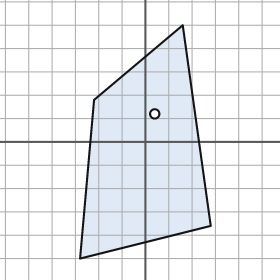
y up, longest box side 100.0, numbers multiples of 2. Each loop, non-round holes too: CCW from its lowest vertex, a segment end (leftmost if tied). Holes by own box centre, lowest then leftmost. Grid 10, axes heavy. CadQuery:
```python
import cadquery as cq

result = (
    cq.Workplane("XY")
    .moveTo(-28.0, -50.0)
    .lineTo(28.0, -36.0)
    .lineTo(16.0, 50.0)
    .lineTo(-22.0, 18.0)
    .close()
    .moveTo(4.0, 12.0)
    .circle(2.0)
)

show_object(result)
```